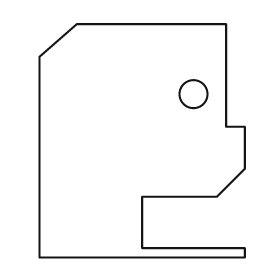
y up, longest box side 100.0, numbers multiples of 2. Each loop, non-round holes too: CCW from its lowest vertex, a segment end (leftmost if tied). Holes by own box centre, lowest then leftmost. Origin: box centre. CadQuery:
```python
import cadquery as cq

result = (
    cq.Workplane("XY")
    .moveTo(-44.0, -50.0)
    .lineTo(44.0, -50.0)
    .lineTo(44.0, -46.0)
    .lineTo(0.0, -46.0)
    .lineTo(0.0, -24.0)
    .lineTo(32.0, -24.0)
    .lineTo(44.0, -12.0)
    .lineTo(44.0, 6.0)
    .lineTo(36.0, 6.0)
    .lineTo(36.0, 50.0)
    .lineTo(-28.0, 50.0)
    .lineTo(-44.0, 36.0)
    .close()
    .moveTo(22.0, 20.0)
    .circle(6.0)
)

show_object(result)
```